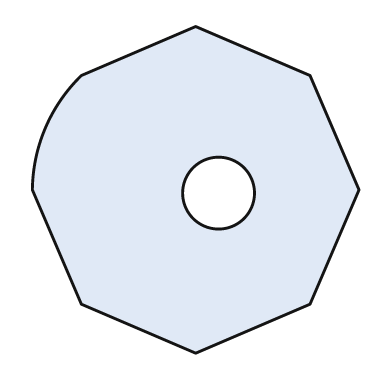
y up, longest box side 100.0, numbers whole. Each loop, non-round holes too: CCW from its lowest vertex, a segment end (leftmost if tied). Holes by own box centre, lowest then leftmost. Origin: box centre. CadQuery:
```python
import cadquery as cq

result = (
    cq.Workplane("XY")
    .moveTo(0.0, -50.0)
    .lineTo(35.0, -35.0)
    .lineTo(50.0, 0.0)
    .lineTo(35.0, 35.0)
    .lineTo(0.0, 50.0)
    .lineTo(-35.0, 35.0)
    .threePointArc((-46.0, 19.0), (-50.0, 0.0))
    .lineTo(-35.0, -35.0)
    .close()
    .moveTo(7.0, -1.0)
    .circle(11.0)
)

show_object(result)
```